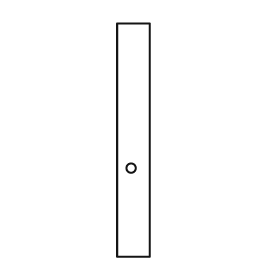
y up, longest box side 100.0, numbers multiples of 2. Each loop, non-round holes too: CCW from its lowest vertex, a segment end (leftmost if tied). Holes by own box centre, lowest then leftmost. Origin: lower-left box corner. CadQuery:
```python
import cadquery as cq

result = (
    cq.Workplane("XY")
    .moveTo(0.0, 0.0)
    .lineTo(14.0, 0.0)
    .lineTo(14.0, 100.0)
    .lineTo(0.0, 100.0)
    .close()
    .moveTo(6.0, 38.0)
    .circle(2.0)
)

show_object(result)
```